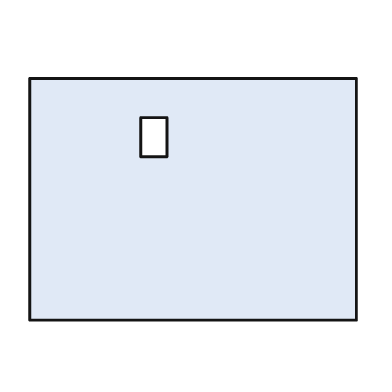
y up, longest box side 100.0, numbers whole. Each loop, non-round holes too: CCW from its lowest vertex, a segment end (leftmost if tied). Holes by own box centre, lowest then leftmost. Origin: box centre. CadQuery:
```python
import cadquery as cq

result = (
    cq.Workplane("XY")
    .moveTo(-50.0, -37.0)
    .lineTo(50.0, -37.0)
    .lineTo(50.0, 37.0)
    .lineTo(-50.0, 37.0)
    .close()
    .moveTo(-16.0, 13.0)
    .lineTo(-8.0, 13.0)
    .lineTo(-8.0, 25.0)
    .lineTo(-16.0, 25.0)
    .close()
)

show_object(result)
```